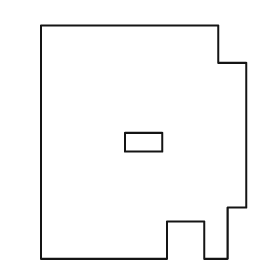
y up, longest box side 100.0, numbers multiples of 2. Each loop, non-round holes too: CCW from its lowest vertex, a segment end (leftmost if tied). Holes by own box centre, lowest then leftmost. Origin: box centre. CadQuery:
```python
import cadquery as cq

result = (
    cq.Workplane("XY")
    .moveTo(-44.0, -50.0)
    .lineTo(10.0, -50.0)
    .lineTo(10.0, -34.0)
    .lineTo(26.0, -34.0)
    .lineTo(26.0, -50.0)
    .lineTo(36.0, -50.0)
    .lineTo(36.0, -28.0)
    .lineTo(44.0, -28.0)
    .lineTo(44.0, 34.0)
    .lineTo(32.0, 34.0)
    .lineTo(32.0, 50.0)
    .lineTo(-44.0, 50.0)
    .close()
    .moveTo(-8.0, -4.0)
    .lineTo(8.0, -4.0)
    .lineTo(8.0, 4.0)
    .lineTo(-8.0, 4.0)
    .close()
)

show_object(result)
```